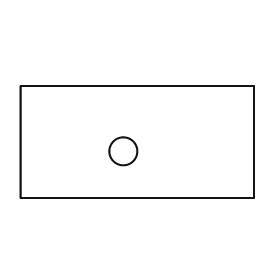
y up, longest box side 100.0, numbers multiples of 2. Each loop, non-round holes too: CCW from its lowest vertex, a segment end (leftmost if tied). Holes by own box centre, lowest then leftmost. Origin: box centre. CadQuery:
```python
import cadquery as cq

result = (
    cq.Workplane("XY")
    .moveTo(-50.0, -24.0)
    .lineTo(50.0, -24.0)
    .lineTo(50.0, 24.0)
    .lineTo(-50.0, 24.0)
    .close()
    .moveTo(-6.0, -4.0)
    .circle(6.0)
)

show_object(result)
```